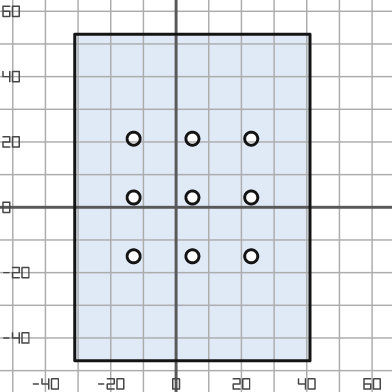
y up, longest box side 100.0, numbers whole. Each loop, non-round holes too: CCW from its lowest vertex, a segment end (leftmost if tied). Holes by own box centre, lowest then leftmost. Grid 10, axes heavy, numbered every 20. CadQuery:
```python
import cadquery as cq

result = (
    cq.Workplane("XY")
    .moveTo(-31.0, -47.0)
    .lineTo(41.0, -47.0)
    .lineTo(41.0, 53.0)
    .lineTo(-31.0, 53.0)
    .close()
    .moveTo(-13.0, -15.0)
    .circle(2.0)
    .moveTo(5.0, -15.0)
    .circle(2.0)
    .moveTo(23.0, -15.0)
    .circle(2.0)
    .moveTo(-13.0, 3.0)
    .circle(2.0)
    .moveTo(5.0, 3.0)
    .circle(2.0)
    .moveTo(23.0, 3.0)
    .circle(2.0)
    .moveTo(-13.0, 21.0)
    .circle(2.0)
    .moveTo(5.0, 21.0)
    .circle(2.0)
    .moveTo(23.0, 21.0)
    .circle(2.0)
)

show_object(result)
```